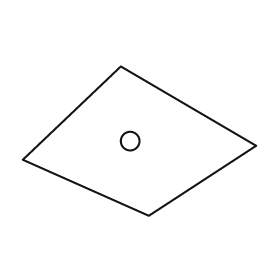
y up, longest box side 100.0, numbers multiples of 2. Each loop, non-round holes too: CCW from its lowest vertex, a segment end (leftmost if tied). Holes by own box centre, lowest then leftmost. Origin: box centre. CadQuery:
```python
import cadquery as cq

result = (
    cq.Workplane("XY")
    .moveTo(4.0, -32.0)
    .lineTo(50.0, -2.0)
    .lineTo(-8.0, 32.0)
    .lineTo(-50.0, -8.0)
    .close()
    .moveTo(-4.0, 0.0)
    .circle(4.0)
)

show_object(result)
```